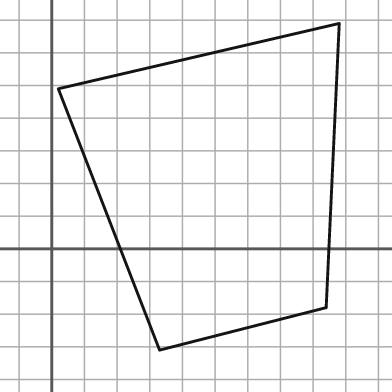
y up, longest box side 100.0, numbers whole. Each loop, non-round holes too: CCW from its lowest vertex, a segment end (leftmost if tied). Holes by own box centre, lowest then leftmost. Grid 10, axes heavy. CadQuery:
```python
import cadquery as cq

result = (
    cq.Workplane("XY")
    .moveTo(33.0, -31.0)
    .lineTo(84.0, -18.0)
    .lineTo(88.0, 69.0)
    .lineTo(2.0, 49.0)
    .close()
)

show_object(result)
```